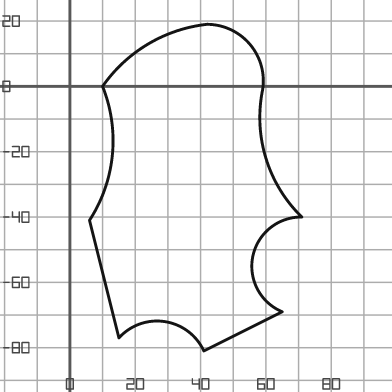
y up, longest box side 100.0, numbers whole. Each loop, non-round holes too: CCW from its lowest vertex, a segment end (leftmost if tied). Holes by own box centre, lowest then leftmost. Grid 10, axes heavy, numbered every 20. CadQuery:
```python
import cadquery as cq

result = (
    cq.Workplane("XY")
    .moveTo(41.0, -81.0)
    .lineTo(65.0, -69.0)
    .threePointArc((56.0, -52.0), (71.0, -40.0))
    .threePointArc((60.0, -22.0), (59.0, -1.0))
    .threePointArc((55.0, 13.0), (42.0, 19.0))
    .threePointArc((24.0, 13.0), (10.0, 0.0))
    .threePointArc((13.0, -21.0), (6.0, -41.0))
    .lineTo(15.0, -77.0)
    .threePointArc((29.0, -72.0), (41.0, -81.0))
    .close()
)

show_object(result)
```